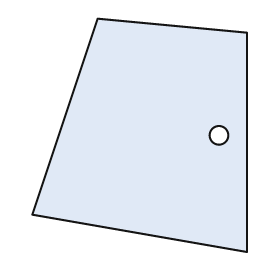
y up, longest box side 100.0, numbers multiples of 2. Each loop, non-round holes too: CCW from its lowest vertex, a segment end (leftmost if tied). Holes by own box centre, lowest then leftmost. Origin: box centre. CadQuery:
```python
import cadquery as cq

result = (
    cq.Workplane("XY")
    .moveTo(46.0, -50.0)
    .lineTo(46.0, 44.0)
    .lineTo(-18.0, 50.0)
    .lineTo(-46.0, -34.0)
    .close()
    .moveTo(34.0, 0.0)
    .circle(4.0)
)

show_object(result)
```